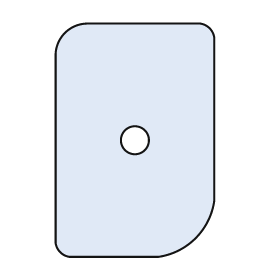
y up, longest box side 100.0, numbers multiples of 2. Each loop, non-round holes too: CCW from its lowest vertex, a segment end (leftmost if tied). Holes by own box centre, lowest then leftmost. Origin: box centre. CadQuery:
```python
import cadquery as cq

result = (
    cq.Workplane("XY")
    .moveTo(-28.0, -50.0)
    .lineTo(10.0, -50.0)
    .threePointArc((26.0, -42.0), (34.0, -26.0))
    .lineTo(34.0, 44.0)
    .threePointArc((32.0, 48.0), (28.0, 50.0))
    .lineTo(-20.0, 50.0)
    .threePointArc((-30.0, 46.0), (-34.0, 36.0))
    .lineTo(-34.0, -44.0)
    .threePointArc((-32.0, -48.0), (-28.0, -50.0))
    .close()
    .moveTo(0.0, 0.0)
    .circle(6.0)
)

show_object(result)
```